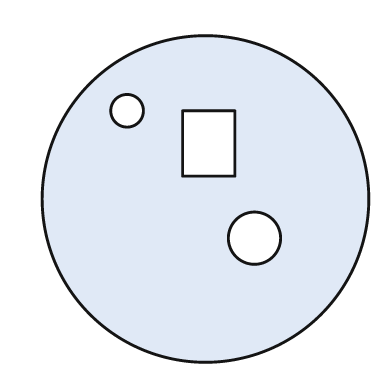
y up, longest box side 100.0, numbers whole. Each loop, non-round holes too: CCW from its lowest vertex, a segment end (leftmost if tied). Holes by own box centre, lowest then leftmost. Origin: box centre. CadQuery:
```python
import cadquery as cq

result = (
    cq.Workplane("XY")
    .moveTo(0.0, 0.0)
    .circle(50.0)
    .moveTo(15.0, -12.0)
    .circle(8.0)
    .moveTo(-7.0, 7.0)
    .lineTo(9.0, 7.0)
    .lineTo(9.0, 27.0)
    .lineTo(-7.0, 27.0)
    .close()
    .moveTo(-24.0, 27.0)
    .circle(5.0)
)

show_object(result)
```